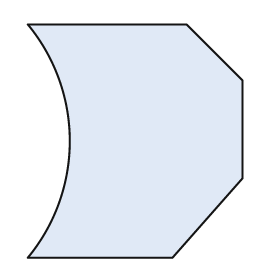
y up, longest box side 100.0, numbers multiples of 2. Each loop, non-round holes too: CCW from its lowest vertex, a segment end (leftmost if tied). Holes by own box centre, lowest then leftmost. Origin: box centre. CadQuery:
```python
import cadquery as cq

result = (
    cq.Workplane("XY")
    .moveTo(-46.0, -50.0)
    .lineTo(16.0, -50.0)
    .lineTo(46.0, -16.0)
    .lineTo(46.0, 26.0)
    .lineTo(22.0, 50.0)
    .lineTo(-46.0, 50.0)
    .threePointArc((-28.0, 0.0), (-46.0, -50.0))
    .close()
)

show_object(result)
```